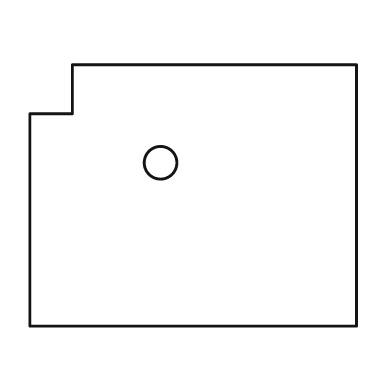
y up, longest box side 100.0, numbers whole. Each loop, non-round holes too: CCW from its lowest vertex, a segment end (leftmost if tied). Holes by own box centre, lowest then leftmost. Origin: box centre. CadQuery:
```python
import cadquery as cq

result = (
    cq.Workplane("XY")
    .moveTo(-50.0, -40.0)
    .lineTo(50.0, -40.0)
    .lineTo(50.0, 40.0)
    .lineTo(-37.0, 40.0)
    .lineTo(-37.0, 25.0)
    .lineTo(-50.0, 25.0)
    .close()
    .moveTo(-10.0, 10.0)
    .circle(5.0)
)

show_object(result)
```